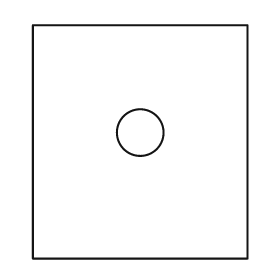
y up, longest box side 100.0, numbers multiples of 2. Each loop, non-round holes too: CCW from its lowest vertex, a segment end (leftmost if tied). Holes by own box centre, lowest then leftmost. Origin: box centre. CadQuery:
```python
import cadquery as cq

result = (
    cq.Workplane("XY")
    .moveTo(-46.0, -50.0)
    .lineTo(46.0, -50.0)
    .lineTo(46.0, 50.0)
    .lineTo(-46.0, 50.0)
    .close()
    .moveTo(0.0, 4.0)
    .circle(10.0)
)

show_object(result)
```